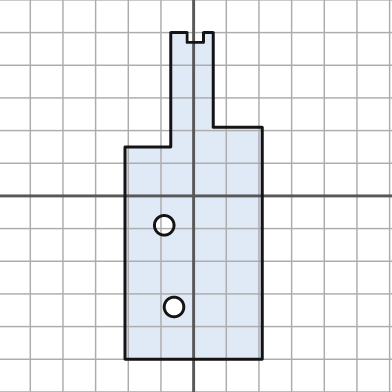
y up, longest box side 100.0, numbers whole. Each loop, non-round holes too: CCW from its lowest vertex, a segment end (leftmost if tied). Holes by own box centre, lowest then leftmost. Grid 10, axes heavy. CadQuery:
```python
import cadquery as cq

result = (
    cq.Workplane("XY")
    .moveTo(-21.0, -50.0)
    .lineTo(21.0, -50.0)
    .lineTo(21.0, 21.0)
    .lineTo(6.0, 21.0)
    .lineTo(6.0, 50.0)
    .lineTo(3.0, 50.0)
    .lineTo(3.0, 47.0)
    .lineTo(-2.0, 47.0)
    .lineTo(-2.0, 50.0)
    .lineTo(-7.0, 50.0)
    .lineTo(-7.0, 15.0)
    .lineTo(-21.0, 15.0)
    .close()
    .moveTo(-6.0, -34.0)
    .circle(3.0)
    .moveTo(-9.0, -9.0)
    .circle(3.0)
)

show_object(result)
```